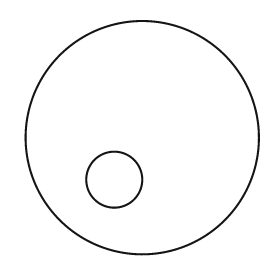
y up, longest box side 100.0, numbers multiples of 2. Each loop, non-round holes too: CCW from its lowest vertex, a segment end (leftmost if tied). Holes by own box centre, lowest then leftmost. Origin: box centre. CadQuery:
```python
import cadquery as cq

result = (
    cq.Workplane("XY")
    .moveTo(0.0, 0.0)
    .circle(50.0)
    .moveTo(-12.0, -18.0)
    .circle(12.0)
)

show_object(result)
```